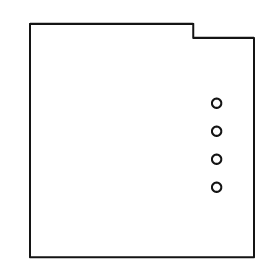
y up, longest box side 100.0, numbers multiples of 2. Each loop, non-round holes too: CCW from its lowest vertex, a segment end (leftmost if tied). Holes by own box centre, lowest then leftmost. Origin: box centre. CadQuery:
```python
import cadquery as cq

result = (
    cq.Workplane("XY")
    .moveTo(-48.0, -50.0)
    .lineTo(48.0, -50.0)
    .lineTo(48.0, 44.0)
    .lineTo(22.0, 44.0)
    .lineTo(22.0, 50.0)
    .lineTo(-48.0, 50.0)
    .close()
    .moveTo(32.0, -20.0)
    .circle(2.0)
    .moveTo(32.0, -8.0)
    .circle(2.0)
    .moveTo(32.0, 4.0)
    .circle(2.0)
    .moveTo(32.0, 16.0)
    .circle(2.0)
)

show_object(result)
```